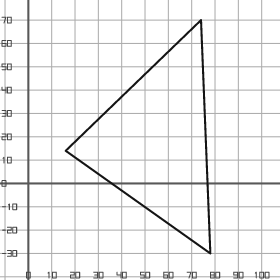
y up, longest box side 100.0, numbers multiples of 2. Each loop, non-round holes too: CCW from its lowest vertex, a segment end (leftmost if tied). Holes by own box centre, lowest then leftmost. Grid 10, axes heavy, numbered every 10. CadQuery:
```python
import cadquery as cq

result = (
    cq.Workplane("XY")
    .moveTo(78.0, -30.0)
    .lineTo(74.0, 70.0)
    .lineTo(16.0, 14.0)
    .close()
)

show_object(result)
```